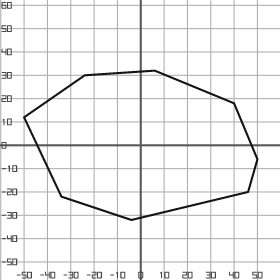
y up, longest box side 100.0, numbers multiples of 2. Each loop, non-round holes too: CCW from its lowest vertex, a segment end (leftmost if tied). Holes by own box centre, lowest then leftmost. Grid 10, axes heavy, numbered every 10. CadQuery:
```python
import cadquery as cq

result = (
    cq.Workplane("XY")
    .moveTo(-4.0, -32.0)
    .lineTo(46.0, -20.0)
    .lineTo(50.0, -6.0)
    .lineTo(40.0, 18.0)
    .lineTo(6.0, 32.0)
    .lineTo(-24.0, 30.0)
    .lineTo(-50.0, 12.0)
    .lineTo(-34.0, -22.0)
    .close()
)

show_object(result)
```